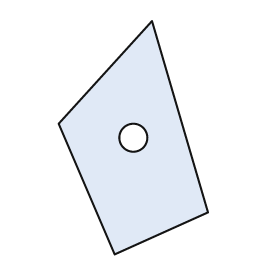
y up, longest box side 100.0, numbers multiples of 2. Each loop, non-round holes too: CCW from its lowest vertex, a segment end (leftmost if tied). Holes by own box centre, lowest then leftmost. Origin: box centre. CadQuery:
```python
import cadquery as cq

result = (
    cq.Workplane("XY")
    .moveTo(-8.0, -50.0)
    .lineTo(32.0, -32.0)
    .lineTo(8.0, 50.0)
    .lineTo(-32.0, 6.0)
    .close()
    .moveTo(0.0, 0.0)
    .circle(6.0)
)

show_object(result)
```